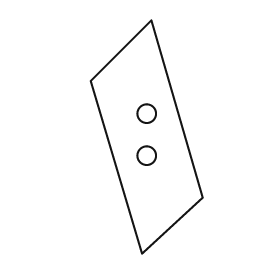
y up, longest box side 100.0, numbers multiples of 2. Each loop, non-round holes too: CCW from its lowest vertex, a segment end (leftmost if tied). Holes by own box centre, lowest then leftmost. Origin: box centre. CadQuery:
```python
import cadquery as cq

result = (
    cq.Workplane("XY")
    .moveTo(-2.0, -50.0)
    .lineTo(24.0, -26.0)
    .lineTo(2.0, 50.0)
    .lineTo(-24.0, 24.0)
    .close()
    .moveTo(0.0, -8.0)
    .circle(4.0)
    .moveTo(0.0, 10.0)
    .circle(4.0)
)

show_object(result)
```